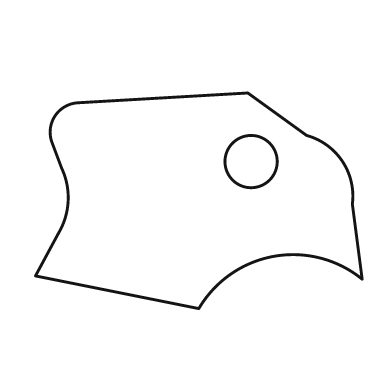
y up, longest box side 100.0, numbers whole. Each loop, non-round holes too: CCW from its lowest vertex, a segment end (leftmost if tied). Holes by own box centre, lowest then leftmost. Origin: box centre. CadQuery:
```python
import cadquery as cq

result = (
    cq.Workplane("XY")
    .moveTo(0.0, -33.0)
    .threePointArc((23.0, -17.0), (50.0, -24.0))
    .lineTo(47.0, -1.0)
    .threePointArc((44.0, 12.0), (33.0, 20.0))
    .lineTo(15.0, 33.0)
    .lineTo(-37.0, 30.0)
    .threePointArc((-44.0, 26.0), (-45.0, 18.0))
    .lineTo(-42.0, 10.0)
    .threePointArc((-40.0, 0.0), (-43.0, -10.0))
    .lineTo(-50.0, -23.0)
    .close()
    .moveTo(16.0, 12.0)
    .circle(8.0)
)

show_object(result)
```